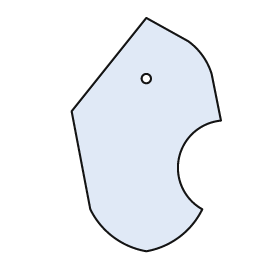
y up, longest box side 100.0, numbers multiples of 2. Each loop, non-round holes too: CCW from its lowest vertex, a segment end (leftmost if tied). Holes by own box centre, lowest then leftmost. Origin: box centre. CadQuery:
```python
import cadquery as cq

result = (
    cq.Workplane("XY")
    .moveTo(0.0, -50.0)
    .threePointArc((14.0, -44.0), (24.0, -32.0))
    .threePointArc((14.0, -10.0), (32.0, 6.0))
    .lineTo(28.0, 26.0)
    .threePointArc((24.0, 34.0), (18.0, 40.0))
    .lineTo(0.0, 50.0)
    .lineTo(-32.0, 10.0)
    .lineTo(-24.0, -32.0)
    .threePointArc((-14.0, -44.0), (0.0, -50.0))
    .close()
    .moveTo(0.0, 24.0)
    .circle(2.0)
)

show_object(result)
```